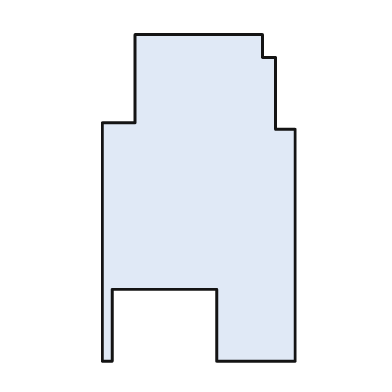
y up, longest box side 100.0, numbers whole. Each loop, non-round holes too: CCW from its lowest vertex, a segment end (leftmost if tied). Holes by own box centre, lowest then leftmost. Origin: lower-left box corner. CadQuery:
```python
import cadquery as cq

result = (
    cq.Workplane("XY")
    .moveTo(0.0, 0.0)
    .lineTo(3.0, 0.0)
    .lineTo(3.0, 22.0)
    .lineTo(35.0, 22.0)
    .lineTo(35.0, 0.0)
    .lineTo(59.0, 0.0)
    .lineTo(59.0, 71.0)
    .lineTo(53.0, 71.0)
    .lineTo(53.0, 93.0)
    .lineTo(49.0, 93.0)
    .lineTo(49.0, 100.0)
    .lineTo(10.0, 100.0)
    .lineTo(10.0, 73.0)
    .lineTo(0.0, 73.0)
    .close()
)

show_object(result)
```